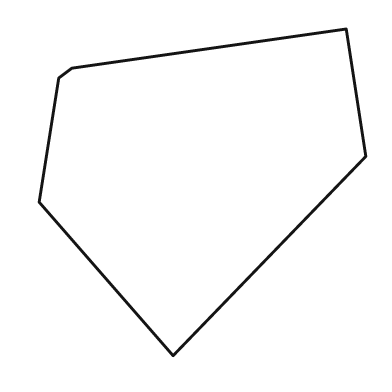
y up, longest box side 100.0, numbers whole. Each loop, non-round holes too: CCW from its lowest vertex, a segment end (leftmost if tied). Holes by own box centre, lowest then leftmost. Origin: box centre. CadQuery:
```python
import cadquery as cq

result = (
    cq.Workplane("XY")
    .moveTo(-9.0, -50.0)
    .lineTo(50.0, 11.0)
    .lineTo(44.0, 50.0)
    .lineTo(-40.0, 38.0)
    .lineTo(-44.0, 35.0)
    .lineTo(-50.0, -3.0)
    .close()
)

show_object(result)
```